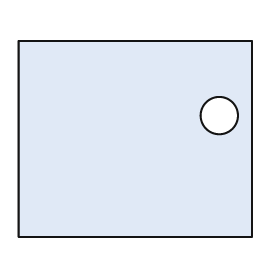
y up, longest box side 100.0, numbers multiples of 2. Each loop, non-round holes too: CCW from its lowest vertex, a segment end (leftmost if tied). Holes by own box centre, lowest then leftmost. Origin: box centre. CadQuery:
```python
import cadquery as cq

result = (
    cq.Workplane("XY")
    .moveTo(-50.0, -42.0)
    .lineTo(50.0, -42.0)
    .lineTo(50.0, 42.0)
    .lineTo(-50.0, 42.0)
    .close()
    .moveTo(36.0, 10.0)
    .circle(8.0)
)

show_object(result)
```